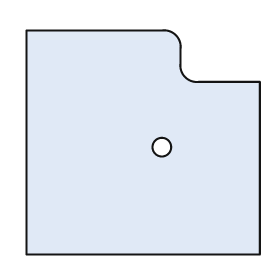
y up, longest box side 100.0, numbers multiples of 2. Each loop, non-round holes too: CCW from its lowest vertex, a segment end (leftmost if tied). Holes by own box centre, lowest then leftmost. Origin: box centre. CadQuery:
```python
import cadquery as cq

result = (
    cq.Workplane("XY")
    .moveTo(-50.0, -48.0)
    .lineTo(50.0, -48.0)
    .lineTo(50.0, 26.0)
    .lineTo(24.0, 26.0)
    .threePointArc((18.0, 28.0), (16.0, 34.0))
    .lineTo(16.0, 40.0)
    .threePointArc((14.0, 46.0), (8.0, 48.0))
    .lineTo(-50.0, 48.0)
    .close()
    .moveTo(8.0, -2.0)
    .circle(4.0)
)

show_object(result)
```